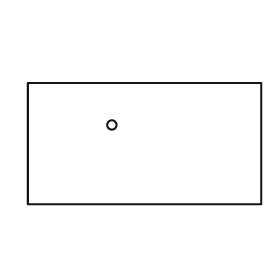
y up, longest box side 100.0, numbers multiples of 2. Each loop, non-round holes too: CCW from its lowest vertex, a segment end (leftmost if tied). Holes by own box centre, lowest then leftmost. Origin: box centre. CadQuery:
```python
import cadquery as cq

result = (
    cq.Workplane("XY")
    .moveTo(-50.0, -26.0)
    .lineTo(50.0, -26.0)
    .lineTo(50.0, 26.0)
    .lineTo(-50.0, 26.0)
    .close()
    .moveTo(-14.0, 8.0)
    .circle(2.0)
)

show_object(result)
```